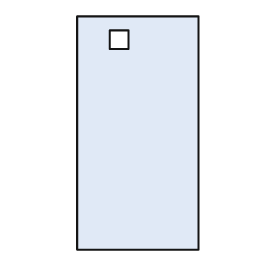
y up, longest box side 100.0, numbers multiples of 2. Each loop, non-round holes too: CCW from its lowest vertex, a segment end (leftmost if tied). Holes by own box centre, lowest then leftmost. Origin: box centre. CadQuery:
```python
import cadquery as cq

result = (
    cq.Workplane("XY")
    .moveTo(-26.0, -50.0)
    .lineTo(26.0, -50.0)
    .lineTo(26.0, 50.0)
    .lineTo(-26.0, 50.0)
    .close()
    .moveTo(-12.0, 36.0)
    .lineTo(-4.0, 36.0)
    .lineTo(-4.0, 44.0)
    .lineTo(-12.0, 44.0)
    .close()
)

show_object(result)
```